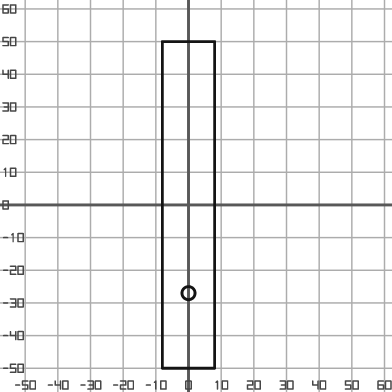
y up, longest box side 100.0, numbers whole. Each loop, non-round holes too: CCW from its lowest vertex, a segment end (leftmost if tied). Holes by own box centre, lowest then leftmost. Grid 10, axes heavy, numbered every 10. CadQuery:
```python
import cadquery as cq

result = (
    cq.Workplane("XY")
    .moveTo(-8.0, -50.0)
    .lineTo(8.0, -50.0)
    .lineTo(8.0, 50.0)
    .lineTo(-8.0, 50.0)
    .close()
    .moveTo(0.0, -27.0)
    .circle(2.0)
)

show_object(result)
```